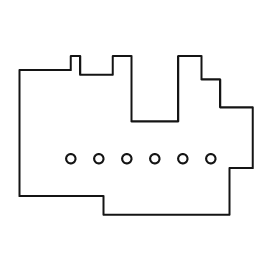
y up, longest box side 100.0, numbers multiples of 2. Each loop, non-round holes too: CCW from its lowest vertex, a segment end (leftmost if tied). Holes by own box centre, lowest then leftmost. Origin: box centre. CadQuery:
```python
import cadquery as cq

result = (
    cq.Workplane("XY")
    .moveTo(-14.0, -34.0)
    .lineTo(40.0, -34.0)
    .lineTo(40.0, -14.0)
    .lineTo(50.0, -14.0)
    .lineTo(50.0, 12.0)
    .lineTo(36.0, 12.0)
    .lineTo(36.0, 24.0)
    .lineTo(28.0, 24.0)
    .lineTo(28.0, 34.0)
    .lineTo(18.0, 34.0)
    .lineTo(18.0, 6.0)
    .lineTo(-2.0, 6.0)
    .lineTo(-2.0, 34.0)
    .lineTo(-10.0, 34.0)
    .lineTo(-10.0, 26.0)
    .lineTo(-24.0, 26.0)
    .lineTo(-24.0, 34.0)
    .lineTo(-28.0, 34.0)
    .lineTo(-28.0, 28.0)
    .lineTo(-50.0, 28.0)
    .lineTo(-50.0, -26.0)
    .lineTo(-14.0, -26.0)
    .close()
    .moveTo(-28.0, -10.0)
    .circle(2.0)
    .moveTo(-16.0, -10.0)
    .circle(2.0)
    .moveTo(-4.0, -10.0)
    .circle(2.0)
    .moveTo(8.0, -10.0)
    .circle(2.0)
    .moveTo(20.0, -10.0)
    .circle(2.0)
    .moveTo(32.0, -10.0)
    .circle(2.0)
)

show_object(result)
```